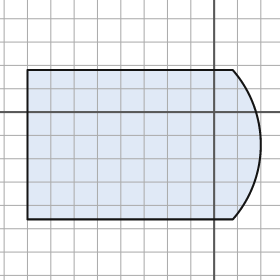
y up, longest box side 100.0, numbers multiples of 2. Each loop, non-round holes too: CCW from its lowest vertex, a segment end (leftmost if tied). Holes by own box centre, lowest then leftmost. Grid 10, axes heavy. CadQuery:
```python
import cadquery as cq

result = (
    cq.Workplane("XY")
    .moveTo(-80.0, -46.0)
    .lineTo(8.0, -46.0)
    .threePointArc((20.0, -14.0), (8.0, 18.0))
    .lineTo(-80.0, 18.0)
    .close()
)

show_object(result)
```